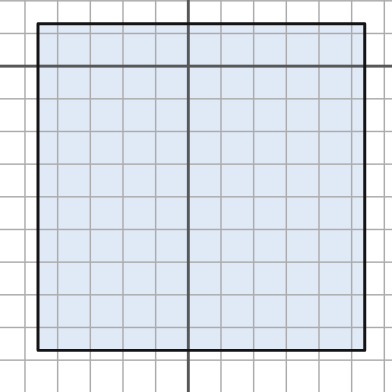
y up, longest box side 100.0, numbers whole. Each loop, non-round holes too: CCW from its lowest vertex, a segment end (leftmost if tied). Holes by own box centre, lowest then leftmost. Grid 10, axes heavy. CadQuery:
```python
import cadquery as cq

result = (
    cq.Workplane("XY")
    .moveTo(-46.0, -87.0)
    .lineTo(54.0, -87.0)
    .lineTo(54.0, 13.0)
    .lineTo(-46.0, 13.0)
    .close()
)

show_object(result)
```